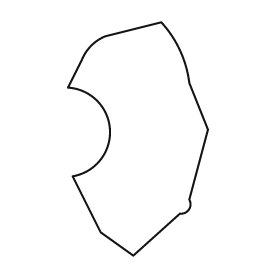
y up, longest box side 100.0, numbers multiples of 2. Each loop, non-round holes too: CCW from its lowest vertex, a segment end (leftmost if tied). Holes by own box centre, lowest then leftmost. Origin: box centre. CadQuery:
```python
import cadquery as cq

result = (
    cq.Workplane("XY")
    .moveTo(-2.0, -50.0)
    .lineTo(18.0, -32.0)
    .threePointArc((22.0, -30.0), (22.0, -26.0))
    .lineTo(30.0, 4.0)
    .lineTo(22.0, 24.0)
    .threePointArc((18.0, 38.0), (10.0, 50.0))
    .lineTo(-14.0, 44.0)
    .threePointArc((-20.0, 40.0), (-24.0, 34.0))
    .lineTo(-30.0, 22.0)
    .threePointArc((-12.0, 4.0), (-28.0, -16.0))
    .lineTo(-16.0, -40.0)
    .close()
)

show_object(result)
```